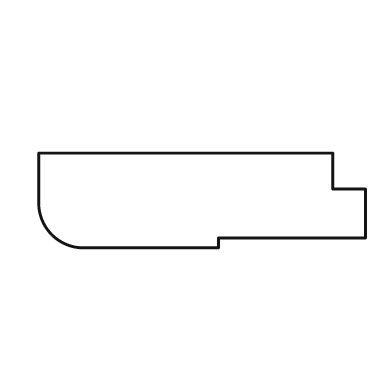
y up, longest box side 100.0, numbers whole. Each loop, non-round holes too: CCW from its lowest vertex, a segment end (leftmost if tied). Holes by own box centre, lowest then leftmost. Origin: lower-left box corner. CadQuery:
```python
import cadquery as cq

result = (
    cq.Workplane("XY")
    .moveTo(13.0, 0.0)
    .lineTo(55.0, 0.0)
    .lineTo(55.0, 3.0)
    .lineTo(100.0, 3.0)
    .lineTo(100.0, 18.0)
    .lineTo(90.0, 18.0)
    .lineTo(90.0, 29.0)
    .lineTo(0.0, 29.0)
    .lineTo(0.0, 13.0)
    .threePointArc((4.0, 4.0), (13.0, 0.0))
    .close()
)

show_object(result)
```